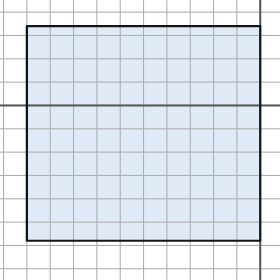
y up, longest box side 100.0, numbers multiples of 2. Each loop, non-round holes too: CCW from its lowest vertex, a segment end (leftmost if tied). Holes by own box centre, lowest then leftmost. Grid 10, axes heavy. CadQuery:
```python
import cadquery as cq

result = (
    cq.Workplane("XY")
    .moveTo(-100.0, -58.0)
    .lineTo(0.0, -58.0)
    .lineTo(0.0, 34.0)
    .lineTo(-100.0, 34.0)
    .close()
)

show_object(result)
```